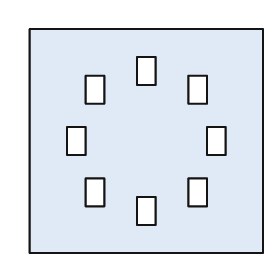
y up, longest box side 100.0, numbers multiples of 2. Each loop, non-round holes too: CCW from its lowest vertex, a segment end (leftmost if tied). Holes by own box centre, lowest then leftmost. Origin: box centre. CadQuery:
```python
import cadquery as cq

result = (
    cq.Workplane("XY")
    .moveTo(-50.0, -48.0)
    .lineTo(50.0, -48.0)
    .lineTo(50.0, 48.0)
    .lineTo(-50.0, 48.0)
    .close()
    .moveTo(-4.0, -36.0)
    .lineTo(4.0, -36.0)
    .lineTo(4.0, -24.0)
    .lineTo(-4.0, -24.0)
    .close()
    .moveTo(-26.0, -28.0)
    .lineTo(-18.0, -28.0)
    .lineTo(-18.0, -16.0)
    .lineTo(-26.0, -16.0)
    .close()
    .moveTo(18.0, -28.0)
    .lineTo(26.0, -28.0)
    .lineTo(26.0, -16.0)
    .lineTo(18.0, -16.0)
    .close()
    .moveTo(-34.0, -6.0)
    .lineTo(-26.0, -6.0)
    .lineTo(-26.0, 6.0)
    .lineTo(-34.0, 6.0)
    .close()
    .moveTo(26.0, -6.0)
    .lineTo(34.0, -6.0)
    .lineTo(34.0, 6.0)
    .lineTo(26.0, 6.0)
    .close()
    .moveTo(-26.0, 16.0)
    .lineTo(-18.0, 16.0)
    .lineTo(-18.0, 28.0)
    .lineTo(-26.0, 28.0)
    .close()
    .moveTo(18.0, 16.0)
    .lineTo(26.0, 16.0)
    .lineTo(26.0, 28.0)
    .lineTo(18.0, 28.0)
    .close()
    .moveTo(-4.0, 24.0)
    .lineTo(4.0, 24.0)
    .lineTo(4.0, 36.0)
    .lineTo(-4.0, 36.0)
    .close()
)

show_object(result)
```